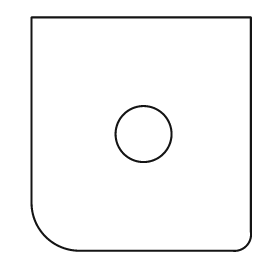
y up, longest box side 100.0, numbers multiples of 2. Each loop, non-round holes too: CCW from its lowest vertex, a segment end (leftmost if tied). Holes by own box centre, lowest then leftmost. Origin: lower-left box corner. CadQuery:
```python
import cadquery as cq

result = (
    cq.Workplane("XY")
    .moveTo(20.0, 0.0)
    .lineTo(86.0, 0.0)
    .threePointArc((92.0, 2.0), (94.0, 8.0))
    .lineTo(94.0, 100.0)
    .lineTo(0.0, 100.0)
    .lineTo(0.0, 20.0)
    .threePointArc((6.0, 6.0), (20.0, 0.0))
    .close()
    .moveTo(48.0, 50.0)
    .circle(12.0)
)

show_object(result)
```